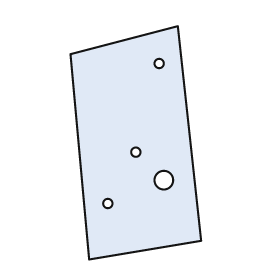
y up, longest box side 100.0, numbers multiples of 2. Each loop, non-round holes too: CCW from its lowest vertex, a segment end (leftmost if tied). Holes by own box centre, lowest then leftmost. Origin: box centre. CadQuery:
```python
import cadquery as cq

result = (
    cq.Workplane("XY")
    .moveTo(-20.0, -50.0)
    .lineTo(28.0, -42.0)
    .lineTo(18.0, 50.0)
    .lineTo(-28.0, 38.0)
    .close()
    .moveTo(-12.0, -26.0)
    .circle(2.0)
    .moveTo(12.0, -16.0)
    .circle(4.0)
    .moveTo(0.0, -4.0)
    .circle(2.0)
    .moveTo(10.0, 34.0)
    .circle(2.0)
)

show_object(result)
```